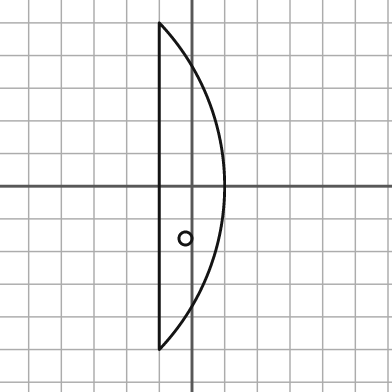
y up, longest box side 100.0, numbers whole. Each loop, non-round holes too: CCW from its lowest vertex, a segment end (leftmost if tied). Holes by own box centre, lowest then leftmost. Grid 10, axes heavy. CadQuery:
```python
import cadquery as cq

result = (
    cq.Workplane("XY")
    .moveTo(-10.0, -50.0)
    .threePointArc((10.0, 0.0), (-10.0, 50.0))
    .close()
    .moveTo(-2.0, -16.0)
    .circle(2.0)
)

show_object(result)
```